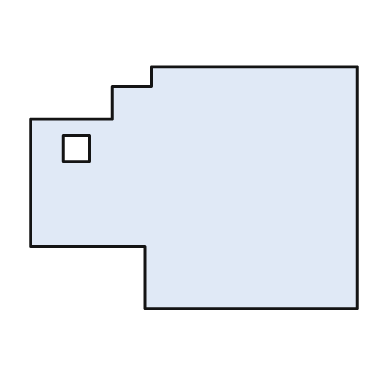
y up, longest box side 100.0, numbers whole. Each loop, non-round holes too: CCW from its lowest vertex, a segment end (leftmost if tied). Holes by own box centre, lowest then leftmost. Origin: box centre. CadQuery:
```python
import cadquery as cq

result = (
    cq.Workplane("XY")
    .moveTo(-15.0, -37.0)
    .lineTo(50.0, -37.0)
    .lineTo(50.0, 37.0)
    .lineTo(-13.0, 37.0)
    .lineTo(-13.0, 31.0)
    .lineTo(-25.0, 31.0)
    .lineTo(-25.0, 21.0)
    .lineTo(-50.0, 21.0)
    .lineTo(-50.0, -18.0)
    .lineTo(-15.0, -18.0)
    .close()
    .moveTo(-40.0, 8.0)
    .lineTo(-32.0, 8.0)
    .lineTo(-32.0, 16.0)
    .lineTo(-40.0, 16.0)
    .close()
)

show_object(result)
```